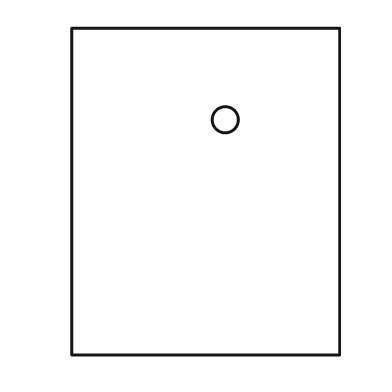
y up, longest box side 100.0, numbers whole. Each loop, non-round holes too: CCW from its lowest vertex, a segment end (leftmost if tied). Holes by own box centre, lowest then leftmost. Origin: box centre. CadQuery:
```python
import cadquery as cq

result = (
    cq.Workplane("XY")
    .moveTo(-41.0, -50.0)
    .lineTo(41.0, -50.0)
    .lineTo(41.0, 50.0)
    .lineTo(-41.0, 50.0)
    .close()
    .moveTo(6.0, 22.0)
    .circle(4.0)
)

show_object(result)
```